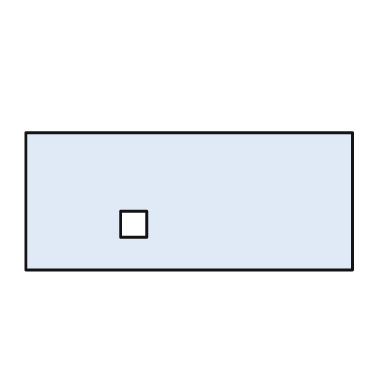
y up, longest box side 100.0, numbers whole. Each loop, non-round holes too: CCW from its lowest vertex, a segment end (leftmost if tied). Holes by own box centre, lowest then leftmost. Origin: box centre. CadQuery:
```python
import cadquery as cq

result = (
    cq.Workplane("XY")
    .moveTo(-50.0, -21.0)
    .lineTo(50.0, -21.0)
    .lineTo(50.0, 21.0)
    .lineTo(-50.0, 21.0)
    .close()
    .moveTo(-21.0, -11.0)
    .lineTo(-13.0, -11.0)
    .lineTo(-13.0, -3.0)
    .lineTo(-21.0, -3.0)
    .close()
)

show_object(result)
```